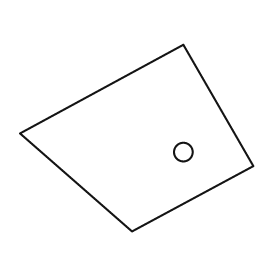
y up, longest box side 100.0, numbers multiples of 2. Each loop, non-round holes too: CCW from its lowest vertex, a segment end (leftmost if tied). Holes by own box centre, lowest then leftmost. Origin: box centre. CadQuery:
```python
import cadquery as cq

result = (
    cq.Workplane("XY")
    .moveTo(-2.0, -40.0)
    .lineTo(50.0, -12.0)
    .lineTo(20.0, 40.0)
    .lineTo(-50.0, 2.0)
    .close()
    .moveTo(20.0, -6.0)
    .circle(4.0)
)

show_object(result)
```